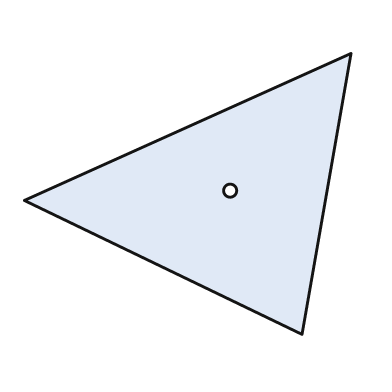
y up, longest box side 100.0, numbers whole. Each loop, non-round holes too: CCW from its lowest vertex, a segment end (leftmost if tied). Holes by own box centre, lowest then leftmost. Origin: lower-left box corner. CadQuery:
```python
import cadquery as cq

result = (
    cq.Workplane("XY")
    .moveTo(85.0, 0.0)
    .lineTo(100.0, 86.0)
    .lineTo(0.0, 41.0)
    .close()
    .moveTo(63.0, 44.0)
    .circle(2.0)
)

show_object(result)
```